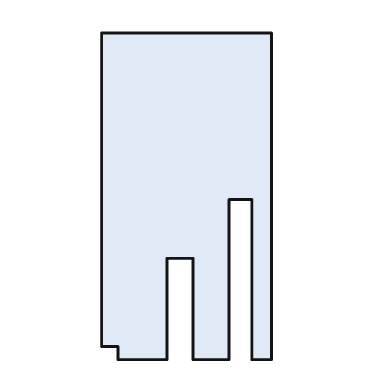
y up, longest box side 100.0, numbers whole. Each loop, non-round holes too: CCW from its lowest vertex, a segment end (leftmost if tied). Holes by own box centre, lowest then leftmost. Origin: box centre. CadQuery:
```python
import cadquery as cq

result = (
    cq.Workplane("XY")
    .moveTo(-21.0, -50.0)
    .lineTo(-6.0, -50.0)
    .lineTo(-6.0, -19.0)
    .lineTo(2.0, -19.0)
    .lineTo(2.0, -50.0)
    .lineTo(13.0, -50.0)
    .lineTo(13.0, -1.0)
    .lineTo(20.0, -1.0)
    .lineTo(20.0, -50.0)
    .lineTo(26.0, -50.0)
    .lineTo(26.0, 50.0)
    .lineTo(-26.0, 50.0)
    .lineTo(-26.0, -46.0)
    .lineTo(-21.0, -46.0)
    .close()
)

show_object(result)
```